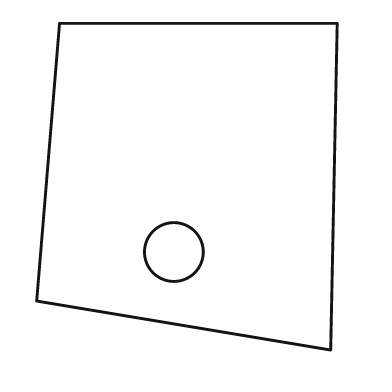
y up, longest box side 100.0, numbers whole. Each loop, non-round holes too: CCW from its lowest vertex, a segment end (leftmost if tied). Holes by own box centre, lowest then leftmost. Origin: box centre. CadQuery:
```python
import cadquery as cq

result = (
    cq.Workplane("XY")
    .moveTo(44.0, -50.0)
    .lineTo(46.0, 50.0)
    .lineTo(-39.0, 50.0)
    .lineTo(-46.0, -35.0)
    .close()
    .moveTo(-4.0, -20.0)
    .circle(9.0)
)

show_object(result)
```